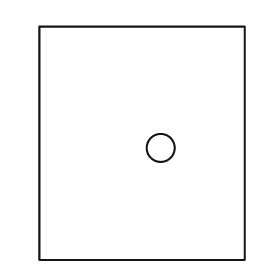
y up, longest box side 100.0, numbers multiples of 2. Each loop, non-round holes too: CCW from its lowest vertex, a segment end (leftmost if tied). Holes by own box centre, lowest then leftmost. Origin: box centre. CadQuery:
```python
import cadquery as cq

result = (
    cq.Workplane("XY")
    .moveTo(-44.0, -50.0)
    .lineTo(44.0, -50.0)
    .lineTo(44.0, 50.0)
    .lineTo(-44.0, 50.0)
    .close()
    .moveTo(8.0, -2.0)
    .circle(6.0)
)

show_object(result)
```